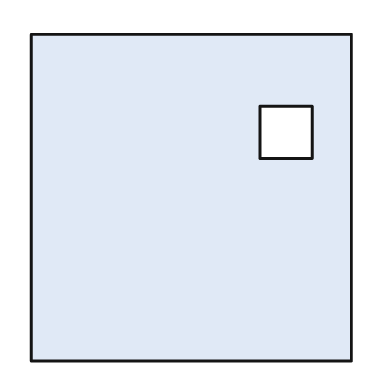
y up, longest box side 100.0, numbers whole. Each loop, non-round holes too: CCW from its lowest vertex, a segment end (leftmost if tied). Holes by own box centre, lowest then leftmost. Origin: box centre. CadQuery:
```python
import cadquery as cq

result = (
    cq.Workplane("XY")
    .moveTo(-49.0, -50.0)
    .lineTo(49.0, -50.0)
    .lineTo(49.0, 50.0)
    .lineTo(-49.0, 50.0)
    .close()
    .moveTo(21.0, 12.0)
    .lineTo(37.0, 12.0)
    .lineTo(37.0, 28.0)
    .lineTo(21.0, 28.0)
    .close()
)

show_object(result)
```